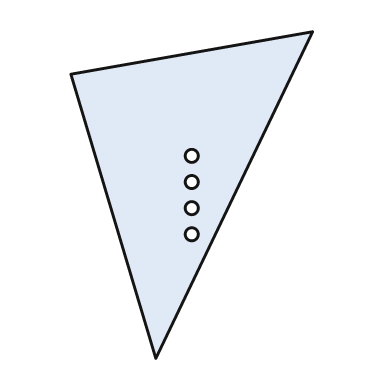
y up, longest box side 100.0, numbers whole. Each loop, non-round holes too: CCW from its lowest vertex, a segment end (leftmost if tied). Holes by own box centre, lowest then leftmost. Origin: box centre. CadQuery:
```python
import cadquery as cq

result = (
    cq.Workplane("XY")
    .moveTo(-11.0, -50.0)
    .lineTo(37.0, 50.0)
    .lineTo(-37.0, 37.0)
    .close()
    .moveTo(0.0, -12.0)
    .circle(2.0)
    .moveTo(0.0, -4.0)
    .circle(2.0)
    .moveTo(0.0, 4.0)
    .circle(2.0)
    .moveTo(0.0, 12.0)
    .circle(2.0)
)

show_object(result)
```